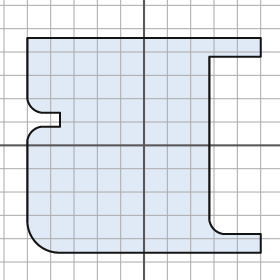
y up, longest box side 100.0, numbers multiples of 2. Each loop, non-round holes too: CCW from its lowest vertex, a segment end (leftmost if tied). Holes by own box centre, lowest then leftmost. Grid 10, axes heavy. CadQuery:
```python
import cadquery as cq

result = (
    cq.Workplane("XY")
    .moveTo(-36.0, -46.0)
    .lineTo(50.0, -46.0)
    .lineTo(50.0, -38.0)
    .lineTo(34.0, -38.0)
    .threePointArc((30.0, -36.0), (28.0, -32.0))
    .lineTo(28.0, 38.0)
    .lineTo(50.0, 38.0)
    .lineTo(50.0, 46.0)
    .lineTo(-50.0, 46.0)
    .lineTo(-50.0, 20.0)
    .threePointArc((-48.0, 16.0), (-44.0, 14.0))
    .lineTo(-36.0, 14.0)
    .lineTo(-36.0, 8.0)
    .lineTo(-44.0, 8.0)
    .threePointArc((-48.0, 6.0), (-50.0, 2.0))
    .lineTo(-50.0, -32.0)
    .threePointArc((-46.0, -42.0), (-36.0, -46.0))
    .close()
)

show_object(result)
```